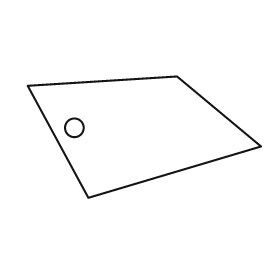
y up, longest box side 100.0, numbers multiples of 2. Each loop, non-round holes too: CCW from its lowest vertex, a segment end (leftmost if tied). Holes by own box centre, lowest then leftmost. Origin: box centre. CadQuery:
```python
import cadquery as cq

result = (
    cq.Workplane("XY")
    .moveTo(-24.0, -26.0)
    .lineTo(50.0, -4.0)
    .lineTo(14.0, 26.0)
    .lineTo(-50.0, 22.0)
    .close()
    .moveTo(-30.0, 4.0)
    .circle(4.0)
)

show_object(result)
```